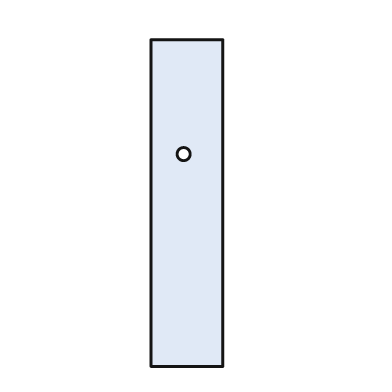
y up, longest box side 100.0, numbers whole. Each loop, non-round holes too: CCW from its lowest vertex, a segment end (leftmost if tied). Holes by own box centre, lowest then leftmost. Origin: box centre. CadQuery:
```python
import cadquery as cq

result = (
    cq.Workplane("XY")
    .moveTo(-11.0, -50.0)
    .lineTo(11.0, -50.0)
    .lineTo(11.0, 50.0)
    .lineTo(-11.0, 50.0)
    .close()
    .moveTo(-1.0, 15.0)
    .circle(2.0)
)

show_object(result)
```